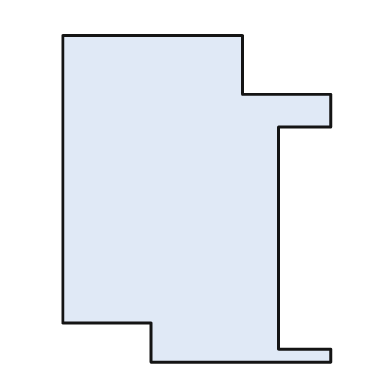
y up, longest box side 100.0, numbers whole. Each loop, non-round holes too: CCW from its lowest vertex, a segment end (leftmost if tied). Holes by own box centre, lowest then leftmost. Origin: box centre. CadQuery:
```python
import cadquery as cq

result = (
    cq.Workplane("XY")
    .moveTo(-14.0, -50.0)
    .lineTo(41.0, -50.0)
    .lineTo(41.0, -46.0)
    .lineTo(25.0, -46.0)
    .lineTo(25.0, 22.0)
    .lineTo(41.0, 22.0)
    .lineTo(41.0, 32.0)
    .lineTo(14.0, 32.0)
    .lineTo(14.0, 50.0)
    .lineTo(-41.0, 50.0)
    .lineTo(-41.0, -38.0)
    .lineTo(-14.0, -38.0)
    .close()
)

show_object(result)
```